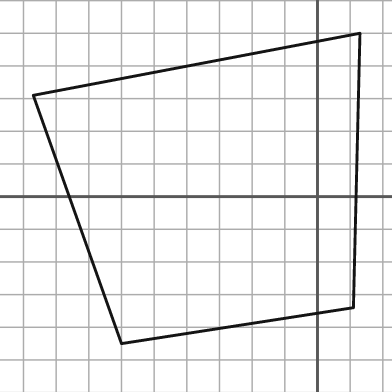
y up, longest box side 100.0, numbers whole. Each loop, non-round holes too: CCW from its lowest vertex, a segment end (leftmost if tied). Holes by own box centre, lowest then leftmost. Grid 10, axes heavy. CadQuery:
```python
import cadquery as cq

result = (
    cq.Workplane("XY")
    .moveTo(-60.0, -45.0)
    .lineTo(11.0, -34.0)
    .lineTo(13.0, 50.0)
    .lineTo(-87.0, 31.0)
    .close()
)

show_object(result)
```